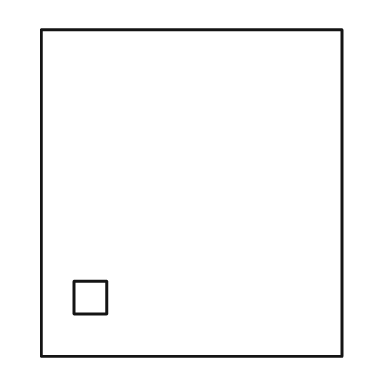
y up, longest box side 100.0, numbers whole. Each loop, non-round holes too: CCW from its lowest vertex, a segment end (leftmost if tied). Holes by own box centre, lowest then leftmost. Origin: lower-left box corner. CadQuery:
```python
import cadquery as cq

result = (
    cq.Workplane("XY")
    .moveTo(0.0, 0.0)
    .lineTo(92.0, 0.0)
    .lineTo(92.0, 100.0)
    .lineTo(0.0, 100.0)
    .close()
    .moveTo(10.0, 13.0)
    .lineTo(20.0, 13.0)
    .lineTo(20.0, 23.0)
    .lineTo(10.0, 23.0)
    .close()
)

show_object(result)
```